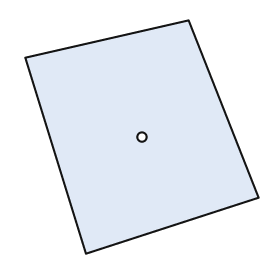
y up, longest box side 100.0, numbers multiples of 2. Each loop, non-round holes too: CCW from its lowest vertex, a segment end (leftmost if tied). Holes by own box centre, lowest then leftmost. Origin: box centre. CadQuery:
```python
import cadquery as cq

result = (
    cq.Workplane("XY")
    .moveTo(-24.0, -50.0)
    .lineTo(50.0, -26.0)
    .lineTo(20.0, 50.0)
    .lineTo(-50.0, 34.0)
    .close()
    .moveTo(0.0, 0.0)
    .circle(2.0)
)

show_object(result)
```